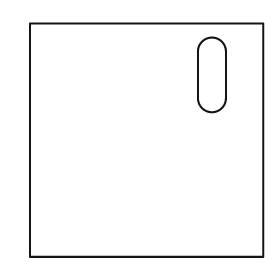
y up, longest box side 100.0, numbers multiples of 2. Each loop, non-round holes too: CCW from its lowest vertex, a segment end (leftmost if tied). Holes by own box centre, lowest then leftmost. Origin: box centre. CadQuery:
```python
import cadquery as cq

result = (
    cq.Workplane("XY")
    .moveTo(-50.0, -50.0)
    .lineTo(50.0, -50.0)
    .lineTo(50.0, 50.0)
    .lineTo(-50.0, 50.0)
    .close()
    .moveTo(22.0, 18.0)
    .threePointArc((28.0, 12.0), (34.0, 18.0))
    .lineTo(34.0, 38.0)
    .threePointArc((28.0, 44.0), (22.0, 38.0))
    .close()
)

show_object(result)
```